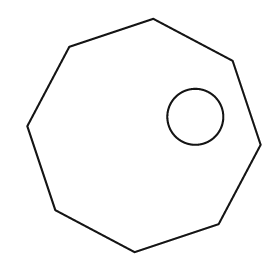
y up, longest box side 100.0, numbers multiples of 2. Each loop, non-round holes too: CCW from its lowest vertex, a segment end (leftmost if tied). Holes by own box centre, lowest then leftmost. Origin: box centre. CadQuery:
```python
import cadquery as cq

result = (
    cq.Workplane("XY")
    .moveTo(-4.0, -50.0)
    .lineTo(32.0, -38.0)
    .lineTo(50.0, -4.0)
    .lineTo(38.0, 32.0)
    .lineTo(4.0, 50.0)
    .lineTo(-32.0, 38.0)
    .lineTo(-50.0, 4.0)
    .lineTo(-38.0, -32.0)
    .close()
    .moveTo(22.0, 8.0)
    .circle(12.0)
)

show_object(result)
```